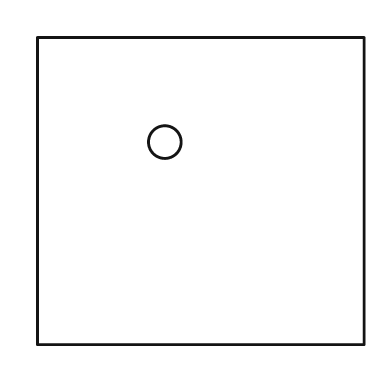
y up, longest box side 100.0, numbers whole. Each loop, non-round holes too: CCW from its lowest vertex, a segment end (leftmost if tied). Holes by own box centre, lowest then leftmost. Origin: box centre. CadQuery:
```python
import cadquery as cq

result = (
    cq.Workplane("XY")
    .moveTo(-50.0, -47.0)
    .lineTo(50.0, -47.0)
    .lineTo(50.0, 47.0)
    .lineTo(-50.0, 47.0)
    .close()
    .moveTo(-11.0, 15.0)
    .circle(5.0)
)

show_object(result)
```